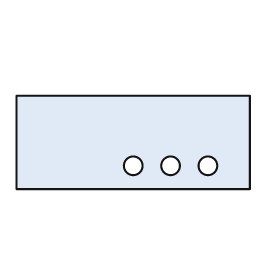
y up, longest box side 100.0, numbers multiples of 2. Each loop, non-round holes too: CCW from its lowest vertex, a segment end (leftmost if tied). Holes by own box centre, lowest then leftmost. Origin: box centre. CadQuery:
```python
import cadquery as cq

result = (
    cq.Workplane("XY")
    .moveTo(-50.0, -20.0)
    .lineTo(50.0, -20.0)
    .lineTo(50.0, 20.0)
    .lineTo(-50.0, 20.0)
    .close()
    .moveTo(0.0, -10.0)
    .circle(4.0)
    .moveTo(16.0, -10.0)
    .circle(4.0)
    .moveTo(32.0, -10.0)
    .circle(4.0)
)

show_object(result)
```